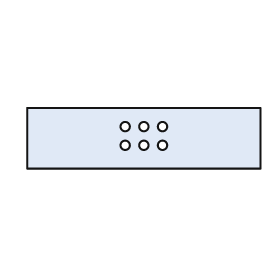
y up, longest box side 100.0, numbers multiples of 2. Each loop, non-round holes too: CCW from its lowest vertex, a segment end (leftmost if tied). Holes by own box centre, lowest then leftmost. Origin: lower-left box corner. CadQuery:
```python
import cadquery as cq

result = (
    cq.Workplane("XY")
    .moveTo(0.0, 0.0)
    .lineTo(100.0, 0.0)
    .lineTo(100.0, 26.0)
    .lineTo(0.0, 26.0)
    .close()
    .moveTo(42.0, 10.0)
    .circle(2.0)
    .moveTo(50.0, 10.0)
    .circle(2.0)
    .moveTo(58.0, 10.0)
    .circle(2.0)
    .moveTo(42.0, 18.0)
    .circle(2.0)
    .moveTo(50.0, 18.0)
    .circle(2.0)
    .moveTo(58.0, 18.0)
    .circle(2.0)
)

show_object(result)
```